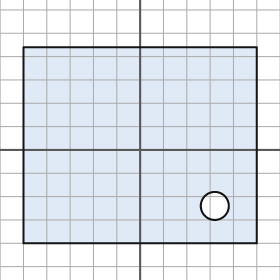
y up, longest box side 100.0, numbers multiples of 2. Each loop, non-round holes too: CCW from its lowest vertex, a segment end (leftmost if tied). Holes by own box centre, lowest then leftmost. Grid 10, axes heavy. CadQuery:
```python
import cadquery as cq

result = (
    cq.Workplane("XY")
    .moveTo(-50.0, -40.0)
    .lineTo(50.0, -40.0)
    .lineTo(50.0, 44.0)
    .lineTo(-50.0, 44.0)
    .close()
    .moveTo(32.0, -24.0)
    .circle(6.0)
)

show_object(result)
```